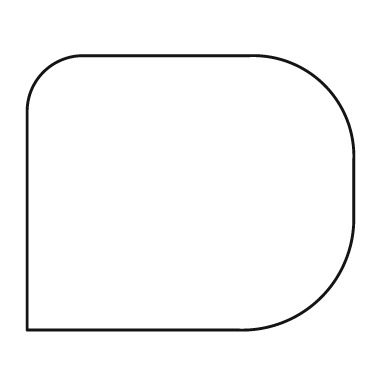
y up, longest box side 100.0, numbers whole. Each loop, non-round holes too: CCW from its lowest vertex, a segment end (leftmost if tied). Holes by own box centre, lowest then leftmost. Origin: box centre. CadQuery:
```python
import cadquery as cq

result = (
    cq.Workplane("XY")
    .moveTo(-50.0, -42.0)
    .lineTo(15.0, -42.0)
    .threePointArc((40.0, -32.0), (50.0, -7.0))
    .lineTo(50.0, 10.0)
    .threePointArc((41.0, 33.0), (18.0, 42.0))
    .lineTo(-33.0, 42.0)
    .threePointArc((-45.0, 37.0), (-50.0, 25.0))
    .close()
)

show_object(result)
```